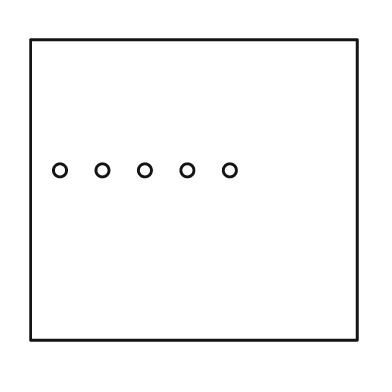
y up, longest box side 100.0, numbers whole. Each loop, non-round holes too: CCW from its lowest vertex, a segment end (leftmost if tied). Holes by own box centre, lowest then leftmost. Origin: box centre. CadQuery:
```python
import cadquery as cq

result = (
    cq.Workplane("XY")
    .moveTo(-50.0, -46.0)
    .lineTo(50.0, -46.0)
    .lineTo(50.0, 46.0)
    .lineTo(-50.0, 46.0)
    .close()
    .moveTo(-41.0, 6.0)
    .circle(2.0)
    .moveTo(-28.0, 6.0)
    .circle(2.0)
    .moveTo(-15.0, 6.0)
    .circle(2.0)
    .moveTo(-2.0, 6.0)
    .circle(2.0)
    .moveTo(11.0, 6.0)
    .circle(2.0)
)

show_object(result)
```